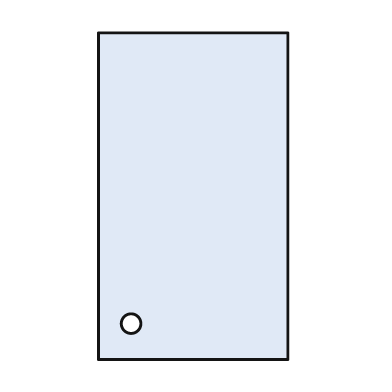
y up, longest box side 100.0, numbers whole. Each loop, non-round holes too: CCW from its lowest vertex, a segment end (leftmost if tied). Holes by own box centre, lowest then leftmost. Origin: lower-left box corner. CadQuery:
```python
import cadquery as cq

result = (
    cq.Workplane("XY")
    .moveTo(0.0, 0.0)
    .lineTo(58.0, 0.0)
    .lineTo(58.0, 100.0)
    .lineTo(0.0, 100.0)
    .close()
    .moveTo(10.0, 11.0)
    .circle(3.0)
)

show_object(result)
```